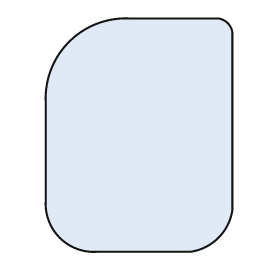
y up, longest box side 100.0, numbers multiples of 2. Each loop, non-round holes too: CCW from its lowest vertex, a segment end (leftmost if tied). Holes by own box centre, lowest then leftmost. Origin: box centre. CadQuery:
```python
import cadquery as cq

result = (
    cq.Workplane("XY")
    .moveTo(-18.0, -50.0)
    .lineTo(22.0, -50.0)
    .threePointArc((34.0, -44.0), (40.0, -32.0))
    .lineTo(40.0, 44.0)
    .threePointArc((38.0, 48.0), (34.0, 50.0))
    .lineTo(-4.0, 50.0)
    .threePointArc((-30.0, 40.0), (-40.0, 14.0))
    .lineTo(-40.0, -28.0)
    .threePointArc((-34.0, -44.0), (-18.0, -50.0))
    .close()
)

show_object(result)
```